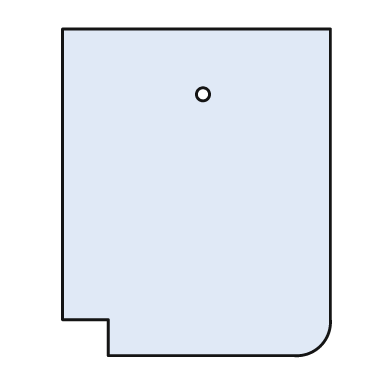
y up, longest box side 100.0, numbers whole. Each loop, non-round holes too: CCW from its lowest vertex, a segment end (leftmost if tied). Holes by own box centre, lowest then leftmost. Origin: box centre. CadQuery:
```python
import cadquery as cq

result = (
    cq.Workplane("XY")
    .moveTo(-27.0, -50.0)
    .lineTo(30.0, -50.0)
    .threePointArc((38.0, -47.0), (41.0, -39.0))
    .lineTo(41.0, 50.0)
    .lineTo(-41.0, 50.0)
    .lineTo(-41.0, -39.0)
    .lineTo(-27.0, -39.0)
    .close()
    .moveTo(2.0, 30.0)
    .circle(2.0)
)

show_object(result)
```